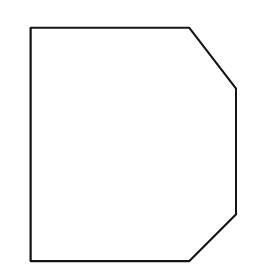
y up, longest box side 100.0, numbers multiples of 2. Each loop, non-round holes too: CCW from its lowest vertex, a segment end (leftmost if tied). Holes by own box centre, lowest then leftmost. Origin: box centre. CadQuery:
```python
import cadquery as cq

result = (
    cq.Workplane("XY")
    .moveTo(-44.0, -50.0)
    .lineTo(24.0, -50.0)
    .lineTo(44.0, -30.0)
    .lineTo(44.0, 24.0)
    .lineTo(24.0, 50.0)
    .lineTo(-44.0, 50.0)
    .close()
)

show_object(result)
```